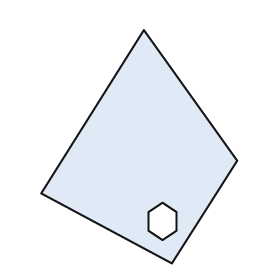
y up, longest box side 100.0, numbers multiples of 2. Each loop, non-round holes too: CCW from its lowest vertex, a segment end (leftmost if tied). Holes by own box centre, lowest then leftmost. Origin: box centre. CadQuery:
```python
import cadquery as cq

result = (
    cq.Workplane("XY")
    .moveTo(14.0, -50.0)
    .lineTo(42.0, -6.0)
    .lineTo(2.0, 50.0)
    .lineTo(-42.0, -20.0)
    .close()
    .moveTo(10.0, -40.0)
    .lineTo(16.0, -36.0)
    .lineTo(16.0, -28.0)
    .lineTo(10.0, -24.0)
    .lineTo(4.0, -28.0)
    .lineTo(4.0, -36.0)
    .close()
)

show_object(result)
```